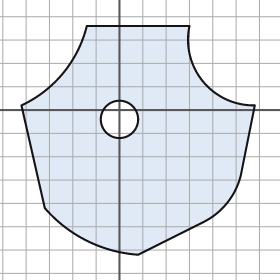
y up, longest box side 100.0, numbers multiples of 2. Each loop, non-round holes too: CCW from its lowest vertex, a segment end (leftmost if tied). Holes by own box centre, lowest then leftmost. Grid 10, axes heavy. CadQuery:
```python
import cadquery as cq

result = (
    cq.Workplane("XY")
    .moveTo(8.0, -62.0)
    .lineTo(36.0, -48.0)
    .threePointArc((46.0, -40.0), (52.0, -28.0))
    .lineTo(58.0, 2.0)
    .threePointArc((36.0, 12.0), (30.0, 36.0))
    .lineTo(-14.0, 36.0)
    .threePointArc((-24.0, 16.0), (-42.0, 2.0))
    .lineTo(-32.0, -42.0)
    .threePointArc((-14.0, -56.0), (8.0, -62.0))
    .close()
    .moveTo(0.0, -4.0)
    .circle(8.0)
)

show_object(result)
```